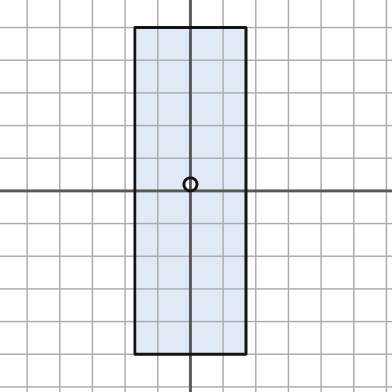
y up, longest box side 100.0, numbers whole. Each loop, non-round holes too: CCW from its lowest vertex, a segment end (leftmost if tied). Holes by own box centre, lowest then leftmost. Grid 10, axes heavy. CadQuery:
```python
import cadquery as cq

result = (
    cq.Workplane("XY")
    .moveTo(-17.0, -50.0)
    .lineTo(17.0, -50.0)
    .lineTo(17.0, 50.0)
    .lineTo(-17.0, 50.0)
    .close()
    .moveTo(0.0, 2.0)
    .circle(2.0)
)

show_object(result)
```